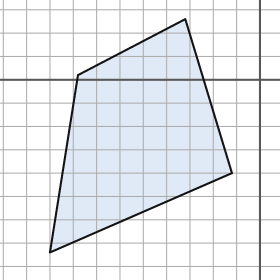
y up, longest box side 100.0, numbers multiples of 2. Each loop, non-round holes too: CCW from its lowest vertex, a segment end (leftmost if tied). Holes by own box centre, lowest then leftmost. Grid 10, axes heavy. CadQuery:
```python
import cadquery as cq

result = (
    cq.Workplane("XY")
    .moveTo(-90.0, -74.0)
    .lineTo(-12.0, -40.0)
    .lineTo(-32.0, 26.0)
    .lineTo(-78.0, 2.0)
    .close()
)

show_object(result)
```